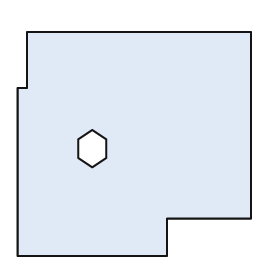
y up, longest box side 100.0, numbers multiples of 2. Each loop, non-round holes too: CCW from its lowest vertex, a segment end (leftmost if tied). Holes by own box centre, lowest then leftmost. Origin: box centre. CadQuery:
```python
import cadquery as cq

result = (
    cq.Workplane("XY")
    .moveTo(-50.0, -48.0)
    .lineTo(14.0, -48.0)
    .lineTo(14.0, -32.0)
    .lineTo(50.0, -32.0)
    .lineTo(50.0, 48.0)
    .lineTo(-46.0, 48.0)
    .lineTo(-46.0, 24.0)
    .lineTo(-50.0, 24.0)
    .close()
    .moveTo(-18.0, -10.0)
    .lineTo(-12.0, -6.0)
    .lineTo(-12.0, 2.0)
    .lineTo(-18.0, 6.0)
    .lineTo(-24.0, 2.0)
    .lineTo(-24.0, -6.0)
    .close()
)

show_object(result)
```